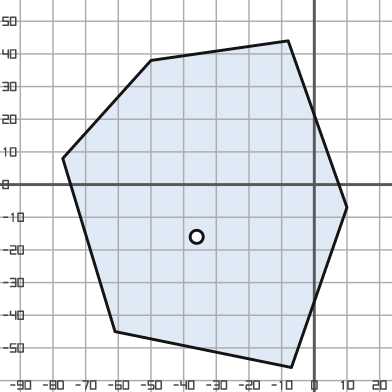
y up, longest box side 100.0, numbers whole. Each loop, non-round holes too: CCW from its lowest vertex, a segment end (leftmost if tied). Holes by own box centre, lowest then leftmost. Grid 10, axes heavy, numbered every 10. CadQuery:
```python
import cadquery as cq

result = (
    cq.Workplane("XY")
    .moveTo(-7.0, -56.0)
    .lineTo(10.0, -7.0)
    .lineTo(-8.0, 44.0)
    .lineTo(-50.0, 38.0)
    .lineTo(-77.0, 8.0)
    .lineTo(-61.0, -45.0)
    .close()
    .moveTo(-36.0, -16.0)
    .circle(2.0)
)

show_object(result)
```